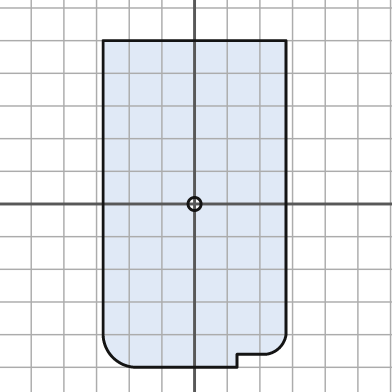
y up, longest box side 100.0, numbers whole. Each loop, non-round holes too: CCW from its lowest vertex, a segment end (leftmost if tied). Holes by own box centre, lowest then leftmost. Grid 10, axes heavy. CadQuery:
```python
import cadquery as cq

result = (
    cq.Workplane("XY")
    .moveTo(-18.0, -50.0)
    .lineTo(13.0, -50.0)
    .lineTo(13.0, -46.0)
    .lineTo(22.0, -46.0)
    .threePointArc((26.0, -44.0), (28.0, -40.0))
    .lineTo(28.0, 50.0)
    .lineTo(-28.0, 50.0)
    .lineTo(-28.0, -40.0)
    .threePointArc((-25.0, -47.0), (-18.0, -50.0))
    .close()
    .moveTo(0.0, 0.0)
    .circle(2.0)
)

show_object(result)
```